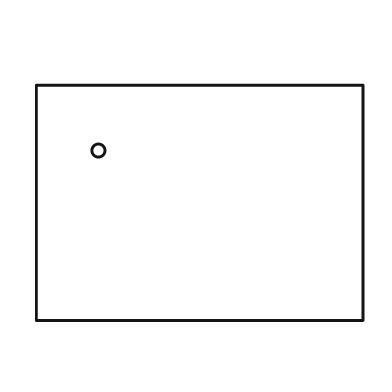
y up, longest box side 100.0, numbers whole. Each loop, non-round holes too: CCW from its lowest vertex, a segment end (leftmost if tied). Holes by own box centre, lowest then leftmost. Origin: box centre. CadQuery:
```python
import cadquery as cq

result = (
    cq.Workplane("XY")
    .moveTo(-50.0, -36.0)
    .lineTo(50.0, -36.0)
    .lineTo(50.0, 36.0)
    .lineTo(-50.0, 36.0)
    .close()
    .moveTo(-31.0, 16.0)
    .circle(2.0)
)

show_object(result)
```